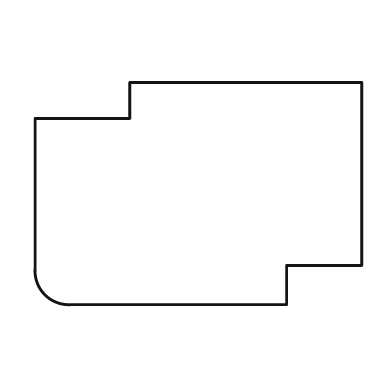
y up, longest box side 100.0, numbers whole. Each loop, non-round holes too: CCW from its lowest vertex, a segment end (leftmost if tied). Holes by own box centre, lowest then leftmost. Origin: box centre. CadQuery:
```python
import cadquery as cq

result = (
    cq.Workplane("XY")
    .moveTo(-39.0, -34.0)
    .lineTo(27.0, -34.0)
    .lineTo(27.0, -22.0)
    .lineTo(50.0, -22.0)
    .lineTo(50.0, 34.0)
    .lineTo(-21.0, 34.0)
    .lineTo(-21.0, 23.0)
    .lineTo(-50.0, 23.0)
    .lineTo(-50.0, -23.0)
    .threePointArc((-47.0, -31.0), (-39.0, -34.0))
    .close()
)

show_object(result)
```